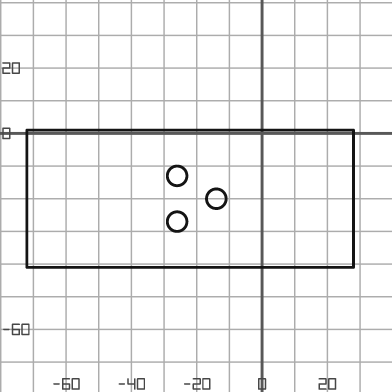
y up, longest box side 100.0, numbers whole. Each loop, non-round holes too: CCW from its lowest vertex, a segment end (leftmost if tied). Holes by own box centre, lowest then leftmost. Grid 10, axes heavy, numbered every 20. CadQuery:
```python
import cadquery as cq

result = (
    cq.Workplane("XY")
    .moveTo(-72.0, -41.0)
    .lineTo(28.0, -41.0)
    .lineTo(28.0, 1.0)
    .lineTo(-72.0, 1.0)
    .close()
    .moveTo(-26.0, -27.0)
    .circle(3.0)
    .moveTo(-14.0, -20.0)
    .circle(3.0)
    .moveTo(-26.0, -13.0)
    .circle(3.0)
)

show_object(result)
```